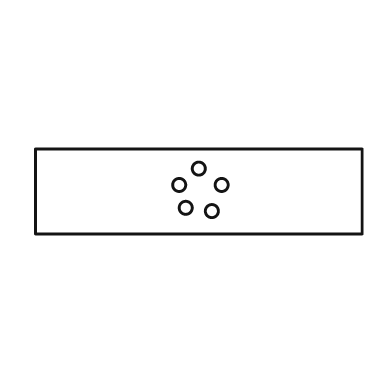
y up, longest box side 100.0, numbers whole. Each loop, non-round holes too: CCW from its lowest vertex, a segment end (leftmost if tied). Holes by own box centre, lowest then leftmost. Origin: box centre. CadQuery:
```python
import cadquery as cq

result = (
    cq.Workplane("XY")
    .moveTo(-50.0, -13.0)
    .lineTo(50.0, -13.0)
    .lineTo(50.0, 13.0)
    .lineTo(-50.0, 13.0)
    .close()
    .moveTo(4.0, -6.0)
    .circle(2.0)
    .moveTo(-4.0, -5.0)
    .circle(2.0)
    .moveTo(-6.0, 2.0)
    .circle(2.0)
    .moveTo(7.0, 2.0)
    .circle(2.0)
    .moveTo(0.0, 7.0)
    .circle(2.0)
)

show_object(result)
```